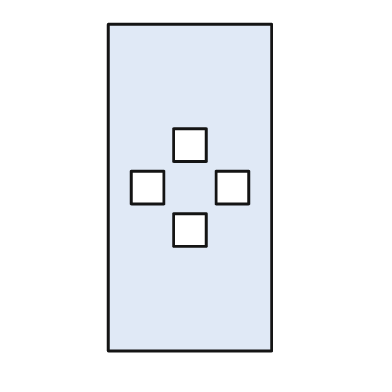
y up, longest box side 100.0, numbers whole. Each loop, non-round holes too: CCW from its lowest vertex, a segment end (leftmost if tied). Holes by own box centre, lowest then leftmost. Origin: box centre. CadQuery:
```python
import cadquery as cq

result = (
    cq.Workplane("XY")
    .moveTo(-25.0, -50.0)
    .lineTo(25.0, -50.0)
    .lineTo(25.0, 50.0)
    .lineTo(-25.0, 50.0)
    .close()
    .moveTo(-5.0, -18.0)
    .lineTo(5.0, -18.0)
    .lineTo(5.0, -8.0)
    .lineTo(-5.0, -8.0)
    .close()
    .moveTo(-18.0, -5.0)
    .lineTo(-8.0, -5.0)
    .lineTo(-8.0, 5.0)
    .lineTo(-18.0, 5.0)
    .close()
    .moveTo(8.0, -5.0)
    .lineTo(18.0, -5.0)
    .lineTo(18.0, 5.0)
    .lineTo(8.0, 5.0)
    .close()
    .moveTo(-5.0, 8.0)
    .lineTo(5.0, 8.0)
    .lineTo(5.0, 18.0)
    .lineTo(-5.0, 18.0)
    .close()
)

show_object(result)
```